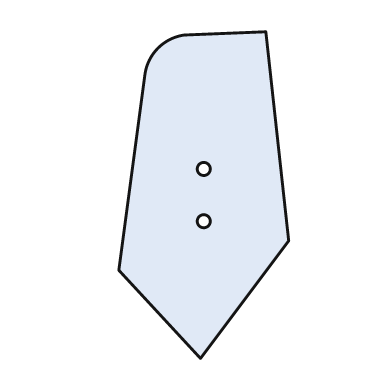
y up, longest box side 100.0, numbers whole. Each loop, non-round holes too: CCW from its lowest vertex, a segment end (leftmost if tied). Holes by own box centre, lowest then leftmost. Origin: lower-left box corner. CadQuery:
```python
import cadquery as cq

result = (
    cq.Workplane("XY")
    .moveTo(25.0, 0.0)
    .lineTo(52.0, 36.0)
    .lineTo(45.0, 100.0)
    .lineTo(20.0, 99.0)
    .threePointArc((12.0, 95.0), (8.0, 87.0))
    .lineTo(0.0, 27.0)
    .close()
    .moveTo(26.0, 42.0)
    .circle(2.0)
    .moveTo(26.0, 58.0)
    .circle(2.0)
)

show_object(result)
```